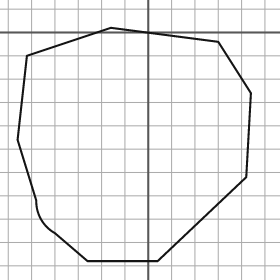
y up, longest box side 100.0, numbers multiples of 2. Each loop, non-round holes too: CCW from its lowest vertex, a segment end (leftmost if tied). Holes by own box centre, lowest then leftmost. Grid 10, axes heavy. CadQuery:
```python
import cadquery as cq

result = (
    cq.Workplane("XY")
    .moveTo(-26.0, -98.0)
    .lineTo(4.0, -98.0)
    .lineTo(42.0, -62.0)
    .lineTo(44.0, -26.0)
    .lineTo(30.0, -4.0)
    .lineTo(-16.0, 2.0)
    .lineTo(-52.0, -10.0)
    .lineTo(-56.0, -46.0)
    .lineTo(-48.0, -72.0)
    .threePointArc((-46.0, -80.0), (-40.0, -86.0))
    .close()
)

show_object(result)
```